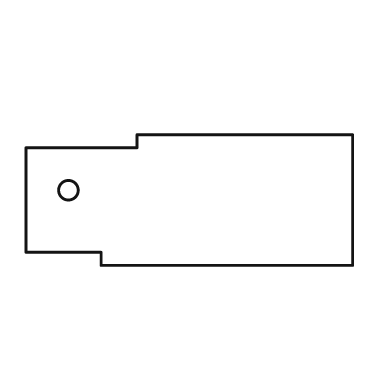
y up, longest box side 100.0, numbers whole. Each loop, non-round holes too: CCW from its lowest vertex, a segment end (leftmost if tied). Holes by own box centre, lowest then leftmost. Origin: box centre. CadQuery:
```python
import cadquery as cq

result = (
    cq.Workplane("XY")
    .moveTo(-27.0, -20.0)
    .lineTo(50.0, -20.0)
    .lineTo(50.0, 20.0)
    .lineTo(-16.0, 20.0)
    .lineTo(-16.0, 16.0)
    .lineTo(-50.0, 16.0)
    .lineTo(-50.0, -16.0)
    .lineTo(-27.0, -16.0)
    .close()
    .moveTo(-37.0, 3.0)
    .circle(3.0)
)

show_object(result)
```